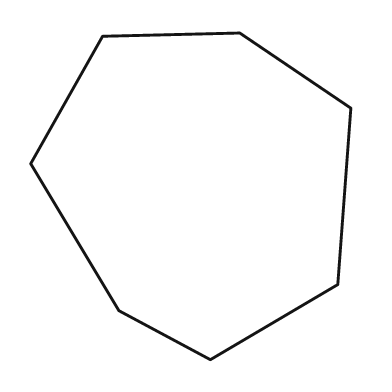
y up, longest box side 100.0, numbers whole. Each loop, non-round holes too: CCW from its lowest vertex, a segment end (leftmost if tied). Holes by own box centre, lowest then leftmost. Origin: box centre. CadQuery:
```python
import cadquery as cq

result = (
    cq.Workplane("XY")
    .moveTo(6.0, -50.0)
    .lineTo(45.0, -27.0)
    .lineTo(49.0, 27.0)
    .lineTo(15.0, 50.0)
    .lineTo(-27.0, 49.0)
    .lineTo(-49.0, 10.0)
    .lineTo(-22.0, -35.0)
    .close()
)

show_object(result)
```